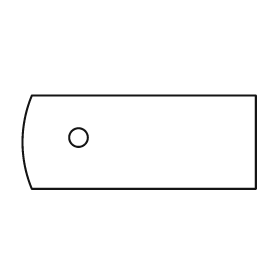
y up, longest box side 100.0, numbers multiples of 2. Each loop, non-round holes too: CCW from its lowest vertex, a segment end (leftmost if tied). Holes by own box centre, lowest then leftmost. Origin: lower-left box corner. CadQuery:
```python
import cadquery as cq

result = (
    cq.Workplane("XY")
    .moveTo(4.0, 0.0)
    .lineTo(100.0, 0.0)
    .lineTo(100.0, 40.0)
    .lineTo(4.0, 40.0)
    .threePointArc((0.0, 20.0), (4.0, 0.0))
    .close()
    .moveTo(24.0, 22.0)
    .circle(4.0)
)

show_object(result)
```